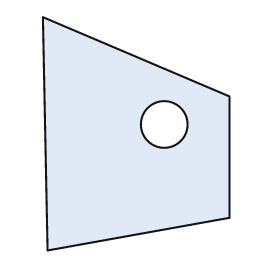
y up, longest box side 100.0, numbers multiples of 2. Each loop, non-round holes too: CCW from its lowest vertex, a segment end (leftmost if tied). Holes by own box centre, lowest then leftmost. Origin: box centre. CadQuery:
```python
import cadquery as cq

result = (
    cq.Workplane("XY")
    .moveTo(-38.0, -50.0)
    .lineTo(40.0, -36.0)
    .lineTo(40.0, 16.0)
    .lineTo(-40.0, 50.0)
    .close()
    .moveTo(12.0, 4.0)
    .circle(10.0)
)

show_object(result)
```